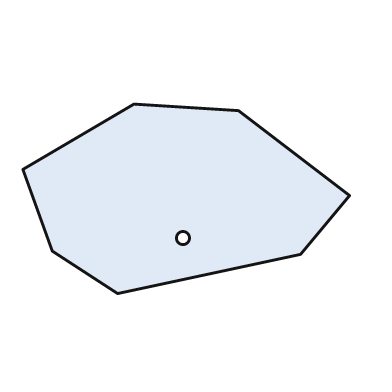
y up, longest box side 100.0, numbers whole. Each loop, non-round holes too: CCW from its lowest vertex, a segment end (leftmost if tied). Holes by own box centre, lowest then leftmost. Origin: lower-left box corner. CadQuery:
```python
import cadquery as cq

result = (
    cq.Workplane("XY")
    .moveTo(29.0, 0.0)
    .lineTo(85.0, 12.0)
    .lineTo(100.0, 30.0)
    .lineTo(66.0, 56.0)
    .lineTo(34.0, 58.0)
    .lineTo(0.0, 38.0)
    .lineTo(9.0, 13.0)
    .close()
    .moveTo(49.0, 17.0)
    .circle(2.0)
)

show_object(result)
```